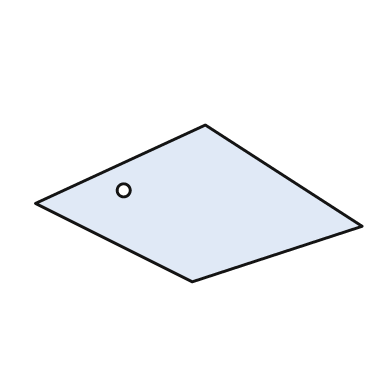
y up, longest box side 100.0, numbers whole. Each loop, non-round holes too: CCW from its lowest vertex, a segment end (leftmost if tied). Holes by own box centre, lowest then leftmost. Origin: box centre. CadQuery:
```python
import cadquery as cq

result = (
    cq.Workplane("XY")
    .moveTo(-2.0, -24.0)
    .lineTo(50.0, -7.0)
    .lineTo(2.0, 24.0)
    .lineTo(-50.0, 0.0)
    .close()
    .moveTo(-23.0, 4.0)
    .circle(2.0)
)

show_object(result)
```